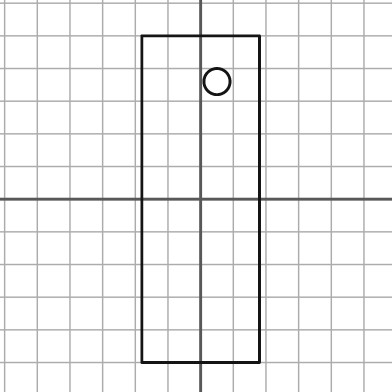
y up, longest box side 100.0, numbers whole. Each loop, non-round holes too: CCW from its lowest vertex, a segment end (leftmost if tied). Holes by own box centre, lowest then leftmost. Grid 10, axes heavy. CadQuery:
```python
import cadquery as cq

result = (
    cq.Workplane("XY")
    .moveTo(-18.0, -50.0)
    .lineTo(18.0, -50.0)
    .lineTo(18.0, 50.0)
    .lineTo(-18.0, 50.0)
    .close()
    .moveTo(5.0, 36.0)
    .circle(4.0)
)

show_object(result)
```